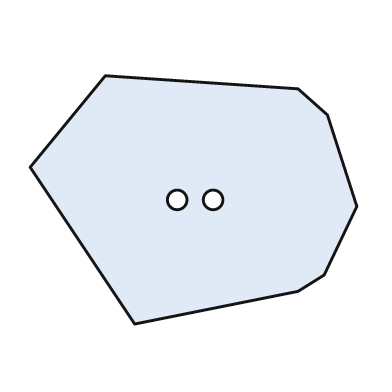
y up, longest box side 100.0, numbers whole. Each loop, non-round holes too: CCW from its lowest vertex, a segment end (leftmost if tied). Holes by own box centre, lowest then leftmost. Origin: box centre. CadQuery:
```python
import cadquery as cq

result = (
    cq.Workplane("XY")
    .moveTo(-18.0, -38.0)
    .lineTo(32.0, -28.0)
    .lineTo(40.0, -23.0)
    .lineTo(50.0, -2.0)
    .lineTo(41.0, 26.0)
    .lineTo(32.0, 34.0)
    .lineTo(-27.0, 38.0)
    .lineTo(-50.0, 10.0)
    .close()
    .moveTo(-5.0, 0.0)
    .circle(3.0)
    .moveTo(6.0, 0.0)
    .circle(3.0)
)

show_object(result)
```